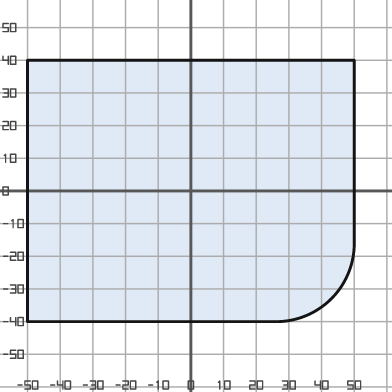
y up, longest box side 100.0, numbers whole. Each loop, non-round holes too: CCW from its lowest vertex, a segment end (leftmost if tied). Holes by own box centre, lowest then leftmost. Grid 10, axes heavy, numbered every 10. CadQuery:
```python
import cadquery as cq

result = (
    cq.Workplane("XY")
    .moveTo(-50.0, -40.0)
    .lineTo(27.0, -40.0)
    .threePointArc((43.0, -33.0), (50.0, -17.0))
    .lineTo(50.0, 40.0)
    .lineTo(-50.0, 40.0)
    .close()
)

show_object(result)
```